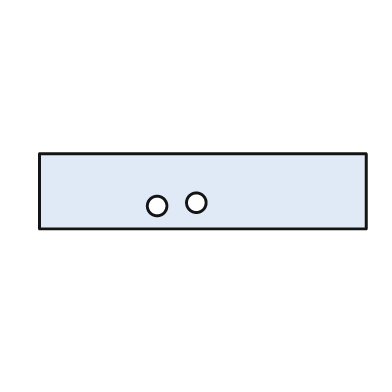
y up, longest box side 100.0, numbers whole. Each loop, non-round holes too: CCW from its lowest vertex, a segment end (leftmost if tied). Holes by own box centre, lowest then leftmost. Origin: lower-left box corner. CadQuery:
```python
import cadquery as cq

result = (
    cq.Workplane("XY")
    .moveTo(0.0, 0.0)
    .lineTo(100.0, 0.0)
    .lineTo(100.0, 23.0)
    .lineTo(0.0, 23.0)
    .close()
    .moveTo(36.0, 7.0)
    .circle(3.0)
    .moveTo(48.0, 8.0)
    .circle(3.0)
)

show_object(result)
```